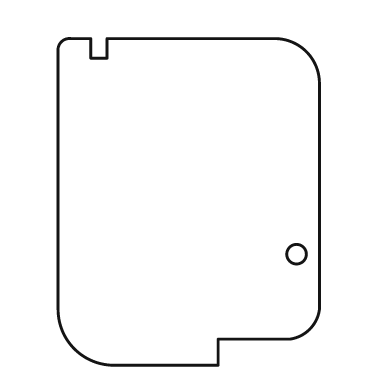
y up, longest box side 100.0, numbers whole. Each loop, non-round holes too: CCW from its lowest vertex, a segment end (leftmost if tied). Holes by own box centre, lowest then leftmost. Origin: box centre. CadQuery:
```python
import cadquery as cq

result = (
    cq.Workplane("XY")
    .moveTo(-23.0, -50.0)
    .lineTo(9.0, -50.0)
    .lineTo(9.0, -42.0)
    .lineTo(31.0, -42.0)
    .threePointArc((37.0, -39.0), (40.0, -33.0))
    .lineTo(40.0, 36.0)
    .threePointArc((36.0, 46.0), (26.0, 50.0))
    .lineTo(-25.0, 50.0)
    .lineTo(-25.0, 44.0)
    .lineTo(-30.0, 44.0)
    .lineTo(-30.0, 50.0)
    .lineTo(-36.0, 50.0)
    .threePointArc((-39.0, 49.0), (-40.0, 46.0))
    .lineTo(-40.0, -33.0)
    .threePointArc((-35.0, -45.0), (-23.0, -50.0))
    .close()
    .moveTo(33.0, -16.0)
    .circle(3.0)
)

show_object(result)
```